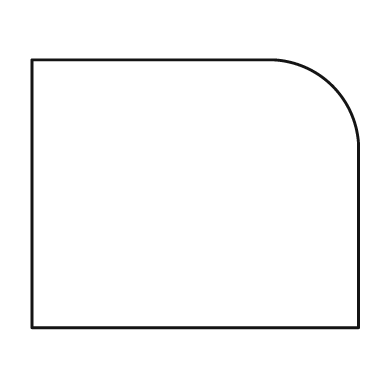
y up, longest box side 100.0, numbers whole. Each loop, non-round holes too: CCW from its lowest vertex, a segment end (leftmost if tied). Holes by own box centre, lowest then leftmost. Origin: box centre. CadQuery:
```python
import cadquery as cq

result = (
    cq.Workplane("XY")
    .moveTo(-50.0, -41.0)
    .lineTo(50.0, -41.0)
    .lineTo(50.0, 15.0)
    .threePointArc((42.0, 33.0), (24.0, 41.0))
    .lineTo(-50.0, 41.0)
    .close()
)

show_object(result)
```